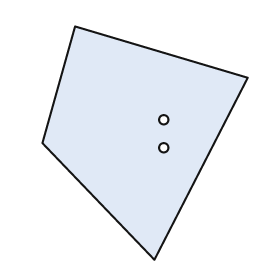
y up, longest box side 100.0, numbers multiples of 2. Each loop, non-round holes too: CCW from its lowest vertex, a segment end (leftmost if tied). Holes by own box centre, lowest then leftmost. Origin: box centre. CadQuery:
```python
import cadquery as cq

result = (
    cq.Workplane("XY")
    .moveTo(4.0, -50.0)
    .lineTo(44.0, 28.0)
    .lineTo(-30.0, 50.0)
    .lineTo(-44.0, 0.0)
    .close()
    .moveTo(8.0, -2.0)
    .circle(2.0)
    .moveTo(8.0, 10.0)
    .circle(2.0)
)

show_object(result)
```